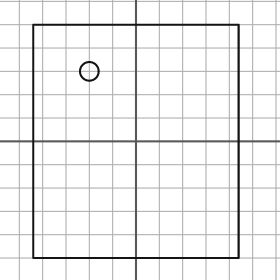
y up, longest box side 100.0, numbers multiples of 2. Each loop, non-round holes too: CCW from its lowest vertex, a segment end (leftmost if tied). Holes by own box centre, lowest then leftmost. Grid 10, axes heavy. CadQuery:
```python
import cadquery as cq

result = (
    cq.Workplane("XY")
    .moveTo(-44.0, -50.0)
    .lineTo(44.0, -50.0)
    .lineTo(44.0, 50.0)
    .lineTo(-44.0, 50.0)
    .close()
    .moveTo(-20.0, 30.0)
    .circle(4.0)
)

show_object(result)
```